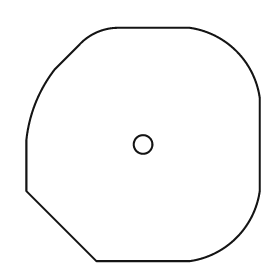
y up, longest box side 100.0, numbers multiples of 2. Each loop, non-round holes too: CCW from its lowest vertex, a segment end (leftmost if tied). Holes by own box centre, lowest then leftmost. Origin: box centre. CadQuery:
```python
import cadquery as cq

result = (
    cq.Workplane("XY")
    .moveTo(-20.0, -50.0)
    .lineTo(20.0, -50.0)
    .threePointArc((40.0, -40.0), (50.0, -20.0))
    .lineTo(50.0, 20.0)
    .threePointArc((40.0, 40.0), (20.0, 50.0))
    .lineTo(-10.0, 50.0)
    .threePointArc((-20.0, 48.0), (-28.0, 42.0))
    .lineTo(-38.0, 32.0)
    .threePointArc((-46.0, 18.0), (-50.0, 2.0))
    .lineTo(-50.0, -20.0)
    .close()
    .moveTo(0.0, 0.0)
    .circle(4.0)
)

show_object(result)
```